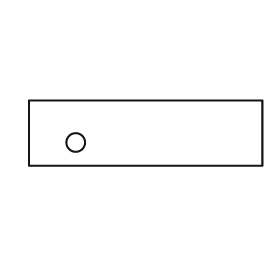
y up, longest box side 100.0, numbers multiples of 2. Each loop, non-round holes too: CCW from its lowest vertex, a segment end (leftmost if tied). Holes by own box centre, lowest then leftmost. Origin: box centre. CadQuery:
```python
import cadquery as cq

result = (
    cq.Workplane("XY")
    .moveTo(-50.0, -14.0)
    .lineTo(50.0, -14.0)
    .lineTo(50.0, 14.0)
    .lineTo(-50.0, 14.0)
    .close()
    .moveTo(-30.0, -4.0)
    .circle(4.0)
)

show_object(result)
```